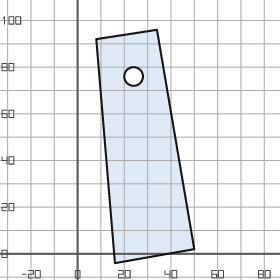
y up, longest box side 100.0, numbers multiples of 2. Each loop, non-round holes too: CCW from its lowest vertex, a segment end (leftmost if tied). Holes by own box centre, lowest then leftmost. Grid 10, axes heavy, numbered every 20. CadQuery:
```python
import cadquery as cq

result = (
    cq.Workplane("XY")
    .moveTo(16.0, -4.0)
    .lineTo(50.0, 2.0)
    .lineTo(34.0, 96.0)
    .lineTo(8.0, 92.0)
    .close()
    .moveTo(24.0, 76.0)
    .circle(4.0)
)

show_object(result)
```